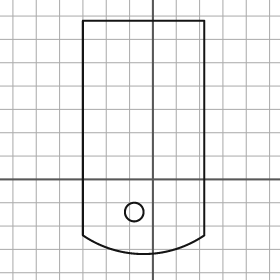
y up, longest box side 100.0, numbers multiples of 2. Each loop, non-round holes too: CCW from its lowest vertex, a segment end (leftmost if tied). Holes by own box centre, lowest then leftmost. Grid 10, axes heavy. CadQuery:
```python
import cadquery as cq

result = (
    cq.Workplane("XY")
    .moveTo(-30.0, -24.0)
    .threePointArc((-4.0, -32.0), (22.0, -24.0))
    .lineTo(22.0, 68.0)
    .lineTo(-30.0, 68.0)
    .close()
    .moveTo(-8.0, -14.0)
    .circle(4.0)
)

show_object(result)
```